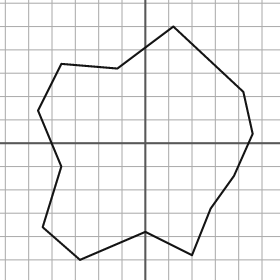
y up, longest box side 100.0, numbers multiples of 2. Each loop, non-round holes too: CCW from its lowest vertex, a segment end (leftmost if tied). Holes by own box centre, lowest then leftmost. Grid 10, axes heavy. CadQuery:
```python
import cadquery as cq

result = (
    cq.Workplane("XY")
    .moveTo(-28.0, -50.0)
    .lineTo(0.0, -38.0)
    .lineTo(20.0, -48.0)
    .lineTo(28.0, -28.0)
    .lineTo(38.0, -14.0)
    .lineTo(46.0, 4.0)
    .lineTo(42.0, 22.0)
    .lineTo(12.0, 50.0)
    .lineTo(-12.0, 32.0)
    .lineTo(-36.0, 34.0)
    .lineTo(-46.0, 14.0)
    .lineTo(-36.0, -10.0)
    .lineTo(-44.0, -36.0)
    .close()
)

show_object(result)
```